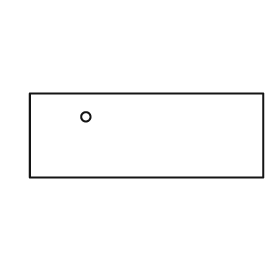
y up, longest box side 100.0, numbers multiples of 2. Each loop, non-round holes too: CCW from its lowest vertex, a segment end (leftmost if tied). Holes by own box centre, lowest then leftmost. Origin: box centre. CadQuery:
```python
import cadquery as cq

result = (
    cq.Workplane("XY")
    .moveTo(-50.0, -18.0)
    .lineTo(50.0, -18.0)
    .lineTo(50.0, 18.0)
    .lineTo(-50.0, 18.0)
    .close()
    .moveTo(-26.0, 8.0)
    .circle(2.0)
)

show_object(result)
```